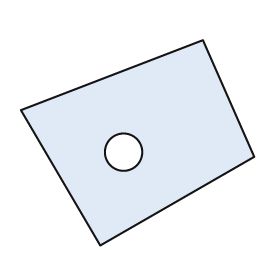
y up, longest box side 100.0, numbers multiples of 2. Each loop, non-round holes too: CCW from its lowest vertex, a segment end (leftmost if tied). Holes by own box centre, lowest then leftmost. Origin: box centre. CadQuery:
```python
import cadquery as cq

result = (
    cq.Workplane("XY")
    .moveTo(-16.0, -44.0)
    .lineTo(50.0, -6.0)
    .lineTo(28.0, 44.0)
    .lineTo(-50.0, 14.0)
    .close()
    .moveTo(-6.0, -4.0)
    .circle(8.0)
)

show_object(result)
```